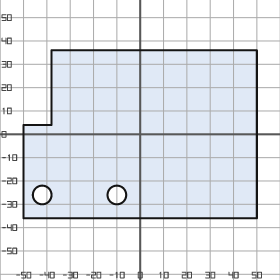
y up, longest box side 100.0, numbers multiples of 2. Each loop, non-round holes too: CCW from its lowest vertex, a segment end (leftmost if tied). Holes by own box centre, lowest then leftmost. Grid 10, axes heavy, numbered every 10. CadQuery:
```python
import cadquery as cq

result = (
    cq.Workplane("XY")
    .moveTo(-50.0, -36.0)
    .lineTo(50.0, -36.0)
    .lineTo(50.0, 36.0)
    .lineTo(-38.0, 36.0)
    .lineTo(-38.0, 4.0)
    .lineTo(-50.0, 4.0)
    .close()
    .moveTo(-42.0, -26.0)
    .circle(4.0)
    .moveTo(-10.0, -26.0)
    .circle(4.0)
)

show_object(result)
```